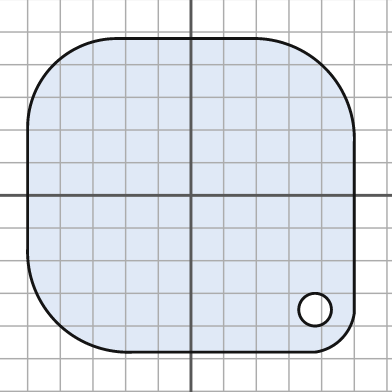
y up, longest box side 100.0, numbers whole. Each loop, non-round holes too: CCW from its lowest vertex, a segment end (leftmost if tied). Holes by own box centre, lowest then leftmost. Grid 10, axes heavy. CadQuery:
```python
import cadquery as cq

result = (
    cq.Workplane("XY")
    .moveTo(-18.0, -48.0)
    .lineTo(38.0, -48.0)
    .threePointArc((46.0, -44.0), (50.0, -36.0))
    .lineTo(50.0, 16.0)
    .threePointArc((41.0, 39.0), (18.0, 48.0))
    .lineTo(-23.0, 48.0)
    .threePointArc((-42.0, 40.0), (-50.0, 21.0))
    .lineTo(-50.0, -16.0)
    .threePointArc((-41.0, -39.0), (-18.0, -48.0))
    .close()
    .moveTo(38.0, -35.0)
    .circle(5.0)
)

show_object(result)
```